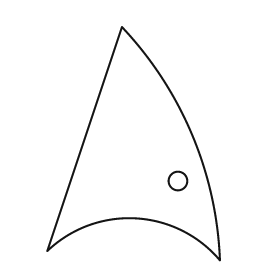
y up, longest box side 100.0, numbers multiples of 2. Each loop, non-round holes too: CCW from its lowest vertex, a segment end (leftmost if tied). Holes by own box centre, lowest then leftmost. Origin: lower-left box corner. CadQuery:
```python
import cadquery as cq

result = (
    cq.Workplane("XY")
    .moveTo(74.0, 0.0)
    .threePointArc((62.0, 54.0), (32.0, 100.0))
    .lineTo(0.0, 4.0)
    .threePointArc((38.0, 18.0), (74.0, 0.0))
    .close()
    .moveTo(56.0, 34.0)
    .circle(4.0)
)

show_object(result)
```